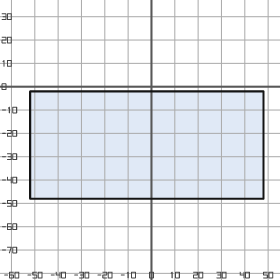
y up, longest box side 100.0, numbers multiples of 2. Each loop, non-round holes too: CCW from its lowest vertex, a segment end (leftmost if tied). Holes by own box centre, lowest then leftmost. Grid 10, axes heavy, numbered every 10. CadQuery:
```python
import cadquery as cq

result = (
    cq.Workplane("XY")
    .moveTo(-52.0, -48.0)
    .lineTo(48.0, -48.0)
    .lineTo(48.0, -2.0)
    .lineTo(-52.0, -2.0)
    .close()
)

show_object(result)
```